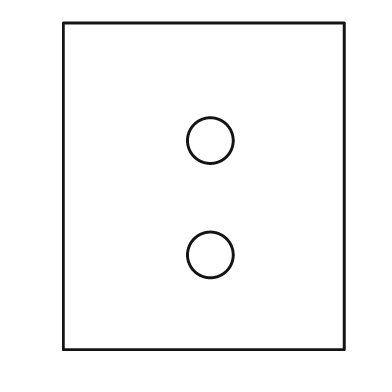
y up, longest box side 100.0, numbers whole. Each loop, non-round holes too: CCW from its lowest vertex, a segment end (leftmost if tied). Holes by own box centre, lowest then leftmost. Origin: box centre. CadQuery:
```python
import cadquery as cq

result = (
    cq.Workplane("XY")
    .moveTo(-43.0, -50.0)
    .lineTo(43.0, -50.0)
    .lineTo(43.0, 50.0)
    .lineTo(-43.0, 50.0)
    .close()
    .moveTo(2.0, -21.0)
    .circle(7.0)
    .moveTo(2.0, 14.0)
    .circle(7.0)
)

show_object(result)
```